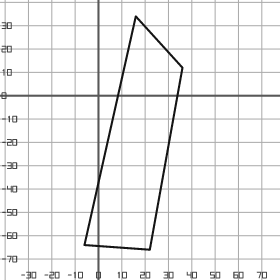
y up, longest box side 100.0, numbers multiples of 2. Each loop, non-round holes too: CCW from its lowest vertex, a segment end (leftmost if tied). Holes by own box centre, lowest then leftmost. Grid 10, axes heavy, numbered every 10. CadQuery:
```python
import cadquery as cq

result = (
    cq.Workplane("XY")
    .moveTo(22.0, -66.0)
    .lineTo(36.0, 12.0)
    .lineTo(16.0, 34.0)
    .lineTo(-6.0, -64.0)
    .close()
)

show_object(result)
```